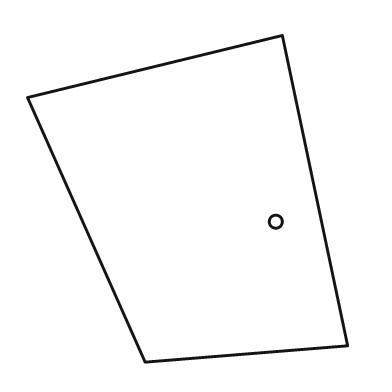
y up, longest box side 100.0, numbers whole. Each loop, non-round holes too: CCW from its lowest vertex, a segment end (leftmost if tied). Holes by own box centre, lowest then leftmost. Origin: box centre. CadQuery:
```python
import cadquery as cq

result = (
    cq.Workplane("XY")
    .moveTo(-13.0, -50.0)
    .lineTo(49.0, -45.0)
    .lineTo(29.0, 50.0)
    .lineTo(-49.0, 31.0)
    .close()
    .moveTo(27.0, -7.0)
    .circle(2.0)
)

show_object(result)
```